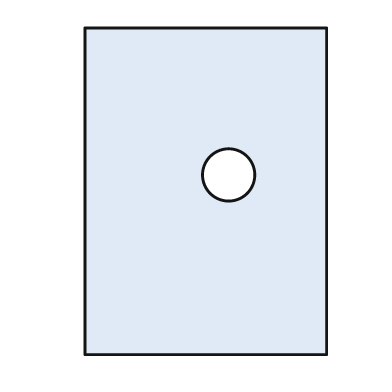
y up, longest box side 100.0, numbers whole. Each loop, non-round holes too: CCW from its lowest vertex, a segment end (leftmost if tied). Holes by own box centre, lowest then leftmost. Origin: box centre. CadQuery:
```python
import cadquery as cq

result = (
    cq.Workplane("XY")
    .moveTo(-37.0, -50.0)
    .lineTo(37.0, -50.0)
    .lineTo(37.0, 50.0)
    .lineTo(-37.0, 50.0)
    .close()
    .moveTo(7.0, 5.0)
    .circle(8.0)
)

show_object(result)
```